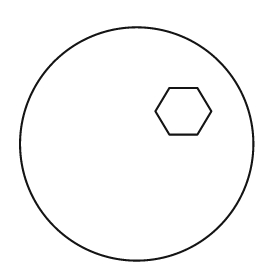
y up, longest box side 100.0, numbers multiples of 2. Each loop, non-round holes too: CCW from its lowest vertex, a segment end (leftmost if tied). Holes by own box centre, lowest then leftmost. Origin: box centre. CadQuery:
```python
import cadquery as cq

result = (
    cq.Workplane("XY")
    .moveTo(0.0, 0.0)
    .circle(50.0)
    .moveTo(14.0, 4.0)
    .lineTo(26.0, 4.0)
    .lineTo(32.0, 14.0)
    .lineTo(26.0, 24.0)
    .lineTo(14.0, 24.0)
    .lineTo(8.0, 14.0)
    .close()
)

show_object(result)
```